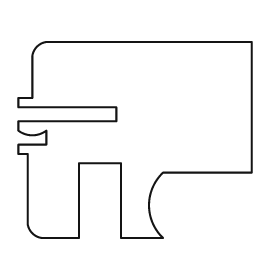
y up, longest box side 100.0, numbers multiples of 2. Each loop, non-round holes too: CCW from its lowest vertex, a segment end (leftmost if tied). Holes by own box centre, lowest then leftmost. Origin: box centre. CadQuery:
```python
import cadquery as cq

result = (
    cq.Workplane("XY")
    .moveTo(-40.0, -42.0)
    .lineTo(-24.0, -42.0)
    .lineTo(-24.0, -10.0)
    .lineTo(-6.0, -10.0)
    .lineTo(-6.0, -42.0)
    .lineTo(12.0, -42.0)
    .threePointArc((6.0, -28.0), (12.0, -14.0))
    .lineTo(50.0, -14.0)
    .lineTo(50.0, 42.0)
    .lineTo(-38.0, 42.0)
    .threePointArc((-42.0, 40.0), (-44.0, 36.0))
    .lineTo(-44.0, 18.0)
    .lineTo(-50.0, 18.0)
    .lineTo(-50.0, 14.0)
    .lineTo(-8.0, 14.0)
    .lineTo(-8.0, 8.0)
    .lineTo(-50.0, 8.0)
    .lineTo(-50.0, 4.0)
    .threePointArc((-44.0, 2.0), (-38.0, 4.0))
    .lineTo(-38.0, -2.0)
    .lineTo(-50.0, -2.0)
    .lineTo(-50.0, -6.0)
    .lineTo(-46.0, -6.0)
    .lineTo(-46.0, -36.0)
    .threePointArc((-44.0, -40.0), (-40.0, -42.0))
    .close()
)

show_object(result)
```